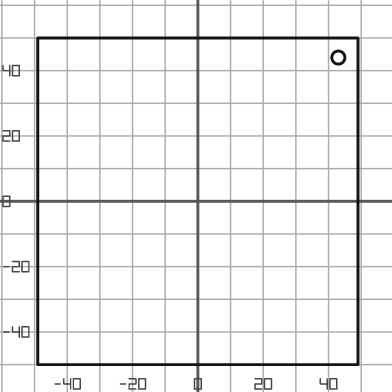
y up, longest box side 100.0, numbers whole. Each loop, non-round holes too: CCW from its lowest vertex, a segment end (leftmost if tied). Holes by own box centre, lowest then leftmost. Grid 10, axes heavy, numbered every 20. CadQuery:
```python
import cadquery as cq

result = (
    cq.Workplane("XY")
    .moveTo(-49.0, -50.0)
    .lineTo(49.0, -50.0)
    .lineTo(49.0, 50.0)
    .lineTo(-49.0, 50.0)
    .close()
    .moveTo(43.0, 44.0)
    .circle(2.0)
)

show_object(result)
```